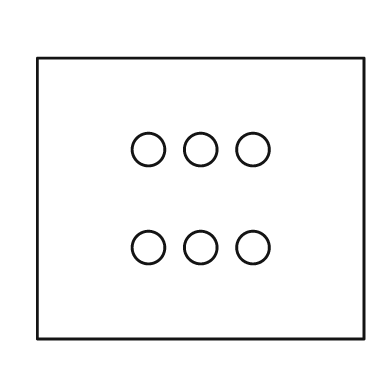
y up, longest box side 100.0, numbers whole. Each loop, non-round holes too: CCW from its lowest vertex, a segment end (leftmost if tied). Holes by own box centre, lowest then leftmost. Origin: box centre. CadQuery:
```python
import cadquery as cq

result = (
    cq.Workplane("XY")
    .moveTo(-50.0, -43.0)
    .lineTo(50.0, -43.0)
    .lineTo(50.0, 43.0)
    .lineTo(-50.0, 43.0)
    .close()
    .moveTo(-16.0, -15.0)
    .circle(5.0)
    .moveTo(0.0, -15.0)
    .circle(5.0)
    .moveTo(16.0, -15.0)
    .circle(5.0)
    .moveTo(-16.0, 15.0)
    .circle(5.0)
    .moveTo(0.0, 15.0)
    .circle(5.0)
    .moveTo(16.0, 15.0)
    .circle(5.0)
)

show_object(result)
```